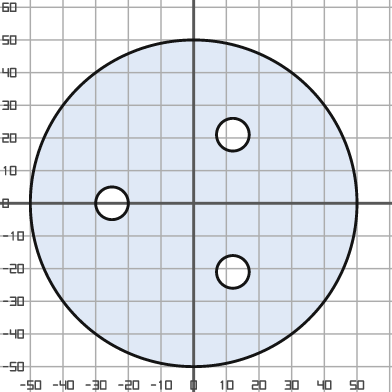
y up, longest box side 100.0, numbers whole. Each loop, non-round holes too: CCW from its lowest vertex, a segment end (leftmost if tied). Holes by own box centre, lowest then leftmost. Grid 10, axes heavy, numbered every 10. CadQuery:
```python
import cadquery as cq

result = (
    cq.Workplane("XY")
    .moveTo(0.0, 0.0)
    .circle(50.0)
    .moveTo(12.0, -21.0)
    .circle(5.0)
    .moveTo(-25.0, 0.0)
    .circle(5.0)
    .moveTo(12.0, 21.0)
    .circle(5.0)
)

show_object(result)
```